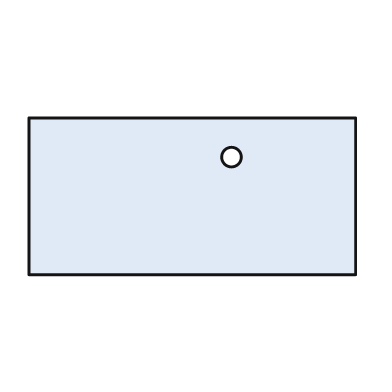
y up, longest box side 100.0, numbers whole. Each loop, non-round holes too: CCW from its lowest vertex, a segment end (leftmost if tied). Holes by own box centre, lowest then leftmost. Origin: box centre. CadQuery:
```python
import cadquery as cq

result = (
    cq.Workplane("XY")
    .moveTo(-50.0, -24.0)
    .lineTo(50.0, -24.0)
    .lineTo(50.0, 24.0)
    .lineTo(-50.0, 24.0)
    .close()
    .moveTo(12.0, 12.0)
    .circle(3.0)
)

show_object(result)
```